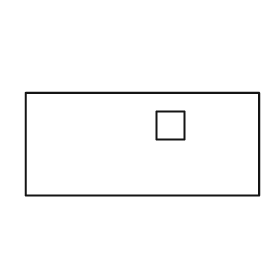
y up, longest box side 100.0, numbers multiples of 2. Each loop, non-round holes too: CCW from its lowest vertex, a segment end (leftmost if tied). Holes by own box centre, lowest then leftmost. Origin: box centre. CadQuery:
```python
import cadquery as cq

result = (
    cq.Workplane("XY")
    .moveTo(-50.0, -22.0)
    .lineTo(50.0, -22.0)
    .lineTo(50.0, 22.0)
    .lineTo(-50.0, 22.0)
    .close()
    .moveTo(6.0, 2.0)
    .lineTo(18.0, 2.0)
    .lineTo(18.0, 14.0)
    .lineTo(6.0, 14.0)
    .close()
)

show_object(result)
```